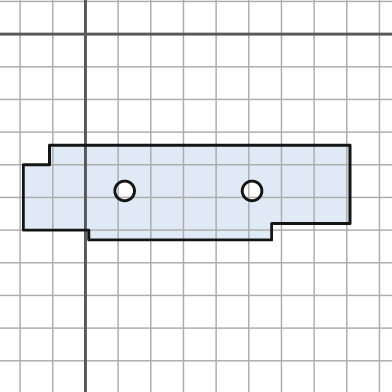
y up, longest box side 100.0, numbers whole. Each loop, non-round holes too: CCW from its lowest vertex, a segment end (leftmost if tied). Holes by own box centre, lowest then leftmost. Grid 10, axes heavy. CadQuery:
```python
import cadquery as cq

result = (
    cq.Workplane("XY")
    .moveTo(1.0, -63.0)
    .lineTo(57.0, -63.0)
    .lineTo(57.0, -58.0)
    .lineTo(81.0, -58.0)
    .lineTo(81.0, -34.0)
    .lineTo(-11.0, -34.0)
    .lineTo(-11.0, -40.0)
    .lineTo(-19.0, -40.0)
    .lineTo(-19.0, -60.0)
    .lineTo(1.0, -60.0)
    .close()
    .moveTo(12.0, -48.0)
    .circle(3.0)
    .moveTo(51.0, -48.0)
    .circle(3.0)
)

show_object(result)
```